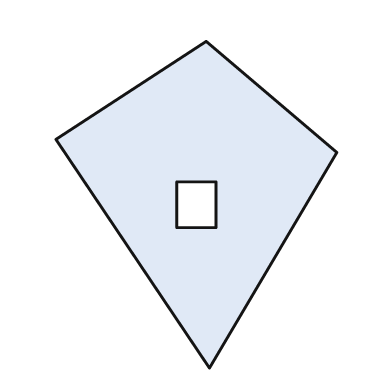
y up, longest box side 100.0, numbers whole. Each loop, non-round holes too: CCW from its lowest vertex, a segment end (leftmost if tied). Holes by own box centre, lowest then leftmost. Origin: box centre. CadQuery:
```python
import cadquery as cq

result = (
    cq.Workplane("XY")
    .moveTo(4.0, -50.0)
    .lineTo(43.0, 16.0)
    .lineTo(3.0, 50.0)
    .lineTo(-43.0, 20.0)
    .close()
    .moveTo(-6.0, -7.0)
    .lineTo(6.0, -7.0)
    .lineTo(6.0, 7.0)
    .lineTo(-6.0, 7.0)
    .close()
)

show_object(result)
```